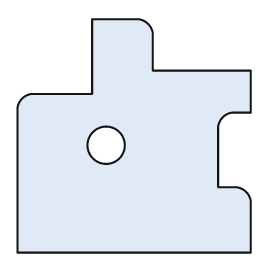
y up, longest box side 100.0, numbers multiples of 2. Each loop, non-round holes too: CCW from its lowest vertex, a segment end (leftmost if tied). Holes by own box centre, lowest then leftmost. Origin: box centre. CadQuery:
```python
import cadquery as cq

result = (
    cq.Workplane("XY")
    .moveTo(-50.0, -50.0)
    .lineTo(50.0, -50.0)
    .lineTo(50.0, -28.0)
    .threePointArc((48.0, -24.0), (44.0, -22.0))
    .lineTo(36.0, -22.0)
    .lineTo(36.0, 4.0)
    .threePointArc((38.0, 8.0), (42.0, 10.0))
    .lineTo(50.0, 10.0)
    .lineTo(50.0, 28.0)
    .lineTo(8.0, 28.0)
    .lineTo(8.0, 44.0)
    .threePointArc((6.0, 48.0), (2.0, 50.0))
    .lineTo(-18.0, 50.0)
    .lineTo(-18.0, 18.0)
    .lineTo(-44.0, 18.0)
    .threePointArc((-48.0, 16.0), (-50.0, 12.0))
    .close()
    .moveTo(-12.0, -4.0)
    .circle(8.0)
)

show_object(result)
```